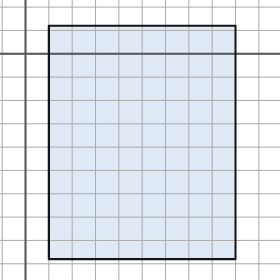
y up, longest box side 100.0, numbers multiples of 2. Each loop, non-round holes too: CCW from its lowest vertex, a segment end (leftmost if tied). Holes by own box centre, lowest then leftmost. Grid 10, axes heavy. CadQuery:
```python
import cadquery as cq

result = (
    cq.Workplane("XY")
    .moveTo(10.0, -88.0)
    .lineTo(90.0, -88.0)
    .lineTo(90.0, 12.0)
    .lineTo(10.0, 12.0)
    .close()
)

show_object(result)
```